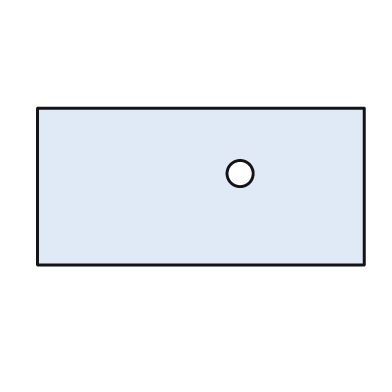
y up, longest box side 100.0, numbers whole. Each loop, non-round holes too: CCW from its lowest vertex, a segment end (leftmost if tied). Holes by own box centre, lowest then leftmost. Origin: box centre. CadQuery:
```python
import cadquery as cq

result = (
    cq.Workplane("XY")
    .moveTo(-50.0, -24.0)
    .lineTo(50.0, -24.0)
    .lineTo(50.0, 24.0)
    .lineTo(-50.0, 24.0)
    .close()
    .moveTo(12.0, 4.0)
    .circle(4.0)
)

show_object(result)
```